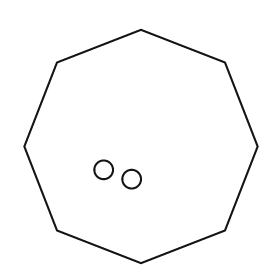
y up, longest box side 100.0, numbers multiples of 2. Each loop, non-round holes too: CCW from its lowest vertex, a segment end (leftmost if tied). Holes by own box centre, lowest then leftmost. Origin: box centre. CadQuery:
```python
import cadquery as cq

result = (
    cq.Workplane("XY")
    .moveTo(0.0, -50.0)
    .lineTo(36.0, -36.0)
    .lineTo(50.0, 0.0)
    .lineTo(36.0, 36.0)
    .lineTo(0.0, 50.0)
    .lineTo(-36.0, 36.0)
    .lineTo(-50.0, 0.0)
    .lineTo(-36.0, -36.0)
    .close()
    .moveTo(-4.0, -14.0)
    .circle(4.0)
    .moveTo(-16.0, -10.0)
    .circle(4.0)
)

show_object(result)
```